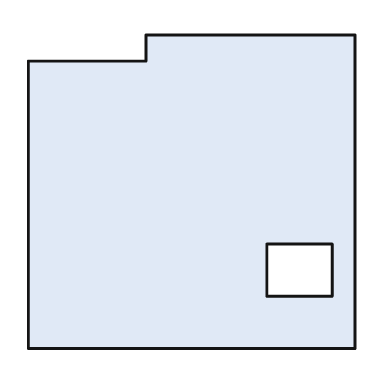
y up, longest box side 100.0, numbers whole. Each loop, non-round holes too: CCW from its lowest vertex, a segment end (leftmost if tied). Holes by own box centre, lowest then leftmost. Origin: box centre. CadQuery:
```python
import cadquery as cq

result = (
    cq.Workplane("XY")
    .moveTo(-50.0, -48.0)
    .lineTo(50.0, -48.0)
    .lineTo(50.0, 48.0)
    .lineTo(-14.0, 48.0)
    .lineTo(-14.0, 40.0)
    .lineTo(-50.0, 40.0)
    .close()
    .moveTo(23.0, -32.0)
    .lineTo(43.0, -32.0)
    .lineTo(43.0, -16.0)
    .lineTo(23.0, -16.0)
    .close()
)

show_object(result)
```